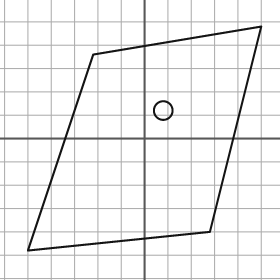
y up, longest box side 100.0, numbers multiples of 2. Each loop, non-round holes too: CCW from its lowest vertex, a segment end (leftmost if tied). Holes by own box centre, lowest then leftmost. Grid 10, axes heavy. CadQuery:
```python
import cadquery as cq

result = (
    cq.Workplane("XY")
    .moveTo(-50.0, -48.0)
    .lineTo(28.0, -40.0)
    .lineTo(50.0, 48.0)
    .lineTo(-22.0, 36.0)
    .close()
    .moveTo(8.0, 12.0)
    .circle(4.0)
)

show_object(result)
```